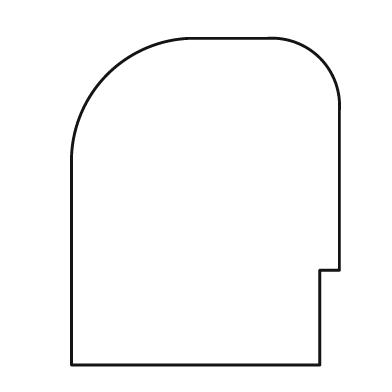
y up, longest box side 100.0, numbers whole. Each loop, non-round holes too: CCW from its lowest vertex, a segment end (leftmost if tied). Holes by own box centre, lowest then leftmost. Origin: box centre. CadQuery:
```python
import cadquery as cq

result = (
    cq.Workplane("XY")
    .moveTo(-41.0, -50.0)
    .lineTo(35.0, -50.0)
    .lineTo(35.0, -21.0)
    .lineTo(41.0, -21.0)
    .lineTo(41.0, 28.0)
    .threePointArc((35.0, 44.0), (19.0, 50.0))
    .lineTo(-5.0, 50.0)
    .threePointArc((-30.0, 39.0), (-41.0, 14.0))
    .close()
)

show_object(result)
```